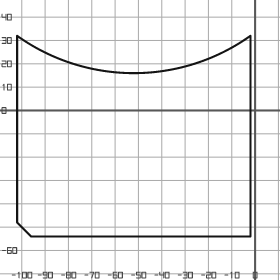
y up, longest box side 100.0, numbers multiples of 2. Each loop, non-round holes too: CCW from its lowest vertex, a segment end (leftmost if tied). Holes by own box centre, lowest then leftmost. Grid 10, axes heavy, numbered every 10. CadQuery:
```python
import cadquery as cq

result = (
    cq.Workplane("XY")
    .moveTo(-96.0, -54.0)
    .lineTo(-2.0, -54.0)
    .lineTo(-2.0, 32.0)
    .threePointArc((-52.0, 16.0), (-102.0, 32.0))
    .lineTo(-102.0, -48.0)
    .close()
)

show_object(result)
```